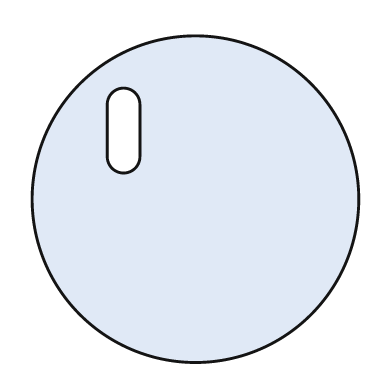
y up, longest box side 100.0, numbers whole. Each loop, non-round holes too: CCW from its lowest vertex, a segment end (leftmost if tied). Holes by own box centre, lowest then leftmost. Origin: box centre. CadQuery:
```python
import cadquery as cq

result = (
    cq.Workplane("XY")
    .moveTo(0.0, 0.0)
    .circle(50.0)
    .moveTo(-27.0, 13.0)
    .threePointArc((-22.0, 8.0), (-17.0, 13.0))
    .lineTo(-17.0, 29.0)
    .threePointArc((-22.0, 34.0), (-27.0, 29.0))
    .close()
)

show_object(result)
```